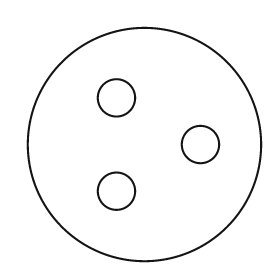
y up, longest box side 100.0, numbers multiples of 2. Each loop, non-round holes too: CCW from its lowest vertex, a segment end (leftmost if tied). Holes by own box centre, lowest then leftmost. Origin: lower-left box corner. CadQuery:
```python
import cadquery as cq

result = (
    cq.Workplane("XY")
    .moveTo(50.0, 50.0)
    .circle(50.0)
    .moveTo(38.0, 30.0)
    .circle(8.0)
    .moveTo(74.0, 50.0)
    .circle(8.0)
    .moveTo(38.0, 70.0)
    .circle(8.0)
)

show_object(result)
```